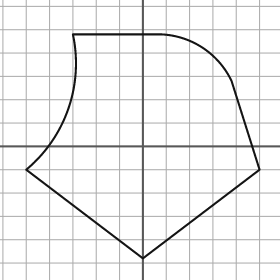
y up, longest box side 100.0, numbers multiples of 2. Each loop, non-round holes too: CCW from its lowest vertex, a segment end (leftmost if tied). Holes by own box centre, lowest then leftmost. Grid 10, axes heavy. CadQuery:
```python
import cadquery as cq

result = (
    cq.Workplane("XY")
    .moveTo(0.0, -48.0)
    .lineTo(50.0, -10.0)
    .lineTo(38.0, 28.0)
    .threePointArc((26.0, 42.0), (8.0, 48.0))
    .lineTo(-30.0, 48.0)
    .threePointArc((-32.0, 16.0), (-50.0, -10.0))
    .close()
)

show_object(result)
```